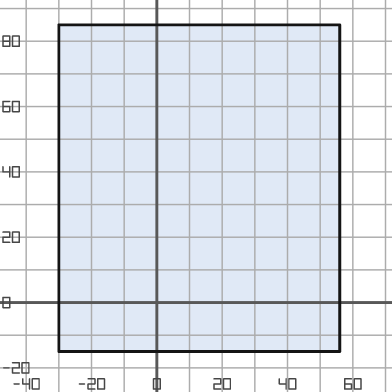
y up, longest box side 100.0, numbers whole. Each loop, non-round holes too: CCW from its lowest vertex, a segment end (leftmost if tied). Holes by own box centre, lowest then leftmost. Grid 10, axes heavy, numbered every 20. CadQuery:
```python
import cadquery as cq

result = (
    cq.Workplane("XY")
    .moveTo(-30.0, -15.0)
    .lineTo(56.0, -15.0)
    .lineTo(56.0, 85.0)
    .lineTo(-30.0, 85.0)
    .close()
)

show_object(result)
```